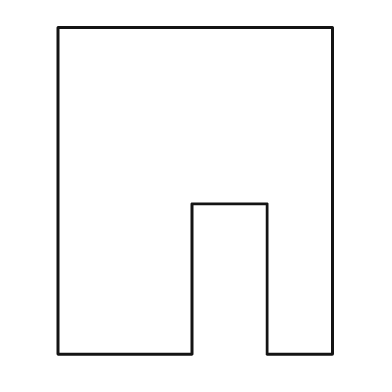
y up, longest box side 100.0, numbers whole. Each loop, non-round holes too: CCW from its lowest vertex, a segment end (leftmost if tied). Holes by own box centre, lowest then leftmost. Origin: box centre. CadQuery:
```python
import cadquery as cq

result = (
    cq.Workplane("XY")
    .moveTo(-42.0, -50.0)
    .lineTo(-1.0, -50.0)
    .lineTo(-1.0, -4.0)
    .lineTo(22.0, -4.0)
    .lineTo(22.0, -50.0)
    .lineTo(42.0, -50.0)
    .lineTo(42.0, 50.0)
    .lineTo(-42.0, 50.0)
    .close()
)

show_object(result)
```